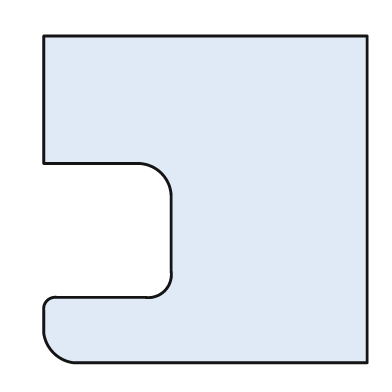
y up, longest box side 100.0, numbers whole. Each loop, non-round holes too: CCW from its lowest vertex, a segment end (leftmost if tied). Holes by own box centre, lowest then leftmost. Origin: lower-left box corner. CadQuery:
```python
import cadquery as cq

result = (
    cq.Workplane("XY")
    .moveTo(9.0, 0.0)
    .lineTo(99.0, 0.0)
    .lineTo(99.0, 100.0)
    .lineTo(0.0, 100.0)
    .lineTo(0.0, 61.0)
    .lineTo(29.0, 61.0)
    .threePointArc((36.0, 58.0), (39.0, 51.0))
    .lineTo(39.0, 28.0)
    .threePointArc((37.0, 22.0), (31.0, 20.0))
    .lineTo(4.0, 20.0)
    .threePointArc((1.0, 19.0), (0.0, 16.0))
    .lineTo(0.0, 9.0)
    .threePointArc((3.0, 3.0), (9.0, 0.0))
    .close()
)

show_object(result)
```